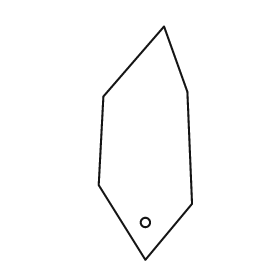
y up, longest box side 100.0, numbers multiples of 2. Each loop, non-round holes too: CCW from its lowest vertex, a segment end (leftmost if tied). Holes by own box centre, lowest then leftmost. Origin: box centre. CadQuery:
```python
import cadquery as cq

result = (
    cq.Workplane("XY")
    .moveTo(0.0, -50.0)
    .lineTo(20.0, -26.0)
    .lineTo(18.0, 22.0)
    .lineTo(8.0, 50.0)
    .lineTo(-18.0, 20.0)
    .lineTo(-20.0, -18.0)
    .close()
    .moveTo(0.0, -34.0)
    .circle(2.0)
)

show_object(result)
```